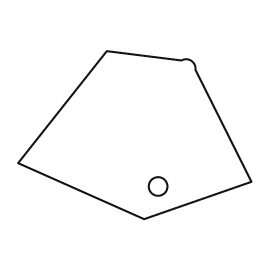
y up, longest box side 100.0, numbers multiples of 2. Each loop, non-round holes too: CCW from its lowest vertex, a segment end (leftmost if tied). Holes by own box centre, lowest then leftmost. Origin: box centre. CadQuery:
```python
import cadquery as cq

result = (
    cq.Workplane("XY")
    .moveTo(4.0, -36.0)
    .lineTo(50.0, -20.0)
    .lineTo(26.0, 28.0)
    .threePointArc((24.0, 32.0), (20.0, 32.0))
    .lineTo(-12.0, 36.0)
    .lineTo(-50.0, -12.0)
    .close()
    .moveTo(10.0, -22.0)
    .circle(4.0)
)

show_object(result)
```